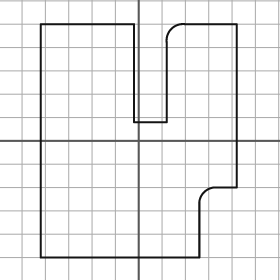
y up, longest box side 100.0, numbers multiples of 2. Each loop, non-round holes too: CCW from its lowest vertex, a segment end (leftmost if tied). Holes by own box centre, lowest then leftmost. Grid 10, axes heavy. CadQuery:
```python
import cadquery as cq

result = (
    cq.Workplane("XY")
    .moveTo(-42.0, -50.0)
    .lineTo(26.0, -50.0)
    .lineTo(26.0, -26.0)
    .threePointArc((28.0, -22.0), (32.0, -20.0))
    .lineTo(42.0, -20.0)
    .lineTo(42.0, 50.0)
    .lineTo(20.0, 50.0)
    .threePointArc((14.0, 48.0), (12.0, 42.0))
    .lineTo(12.0, 8.0)
    .lineTo(-2.0, 8.0)
    .lineTo(-2.0, 50.0)
    .lineTo(-42.0, 50.0)
    .close()
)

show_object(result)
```